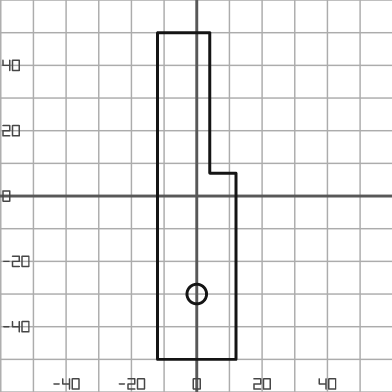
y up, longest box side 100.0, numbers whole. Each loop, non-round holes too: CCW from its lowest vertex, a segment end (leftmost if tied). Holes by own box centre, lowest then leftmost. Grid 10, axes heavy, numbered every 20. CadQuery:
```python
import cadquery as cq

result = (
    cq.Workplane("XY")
    .moveTo(-12.0, -50.0)
    .lineTo(12.0, -50.0)
    .lineTo(12.0, 7.0)
    .lineTo(4.0, 7.0)
    .lineTo(4.0, 50.0)
    .lineTo(-12.0, 50.0)
    .close()
    .moveTo(0.0, -30.0)
    .circle(3.0)
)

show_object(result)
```